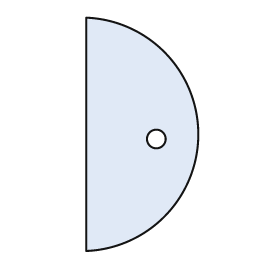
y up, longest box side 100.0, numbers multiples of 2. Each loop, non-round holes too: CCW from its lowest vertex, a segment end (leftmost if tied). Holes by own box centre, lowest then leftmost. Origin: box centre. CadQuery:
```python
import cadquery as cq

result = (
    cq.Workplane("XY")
    .moveTo(-24.0, -50.0)
    .threePointArc((24.0, 0.0), (-24.0, 50.0))
    .close()
    .moveTo(6.0, -2.0)
    .circle(4.0)
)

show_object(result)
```